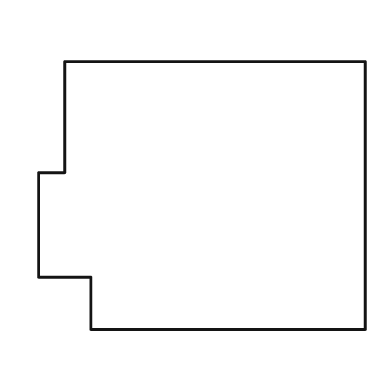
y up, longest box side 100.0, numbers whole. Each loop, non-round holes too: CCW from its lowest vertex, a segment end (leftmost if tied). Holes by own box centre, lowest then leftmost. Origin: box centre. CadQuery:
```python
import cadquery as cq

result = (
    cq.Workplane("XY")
    .moveTo(-34.0, -41.0)
    .lineTo(50.0, -41.0)
    .lineTo(50.0, 41.0)
    .lineTo(-42.0, 41.0)
    .lineTo(-42.0, 7.0)
    .lineTo(-50.0, 7.0)
    .lineTo(-50.0, -25.0)
    .lineTo(-34.0, -25.0)
    .close()
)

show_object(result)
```